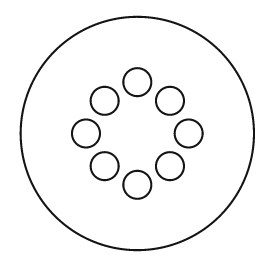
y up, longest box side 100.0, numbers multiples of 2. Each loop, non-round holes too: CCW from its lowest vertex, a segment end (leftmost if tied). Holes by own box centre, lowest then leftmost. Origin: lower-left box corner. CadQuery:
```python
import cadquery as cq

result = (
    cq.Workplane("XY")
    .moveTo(50.0, 50.0)
    .circle(50.0)
    .moveTo(50.0, 28.0)
    .circle(6.0)
    .moveTo(36.0, 36.0)
    .circle(6.0)
    .moveTo(64.0, 36.0)
    .circle(6.0)
    .moveTo(28.0, 50.0)
    .circle(6.0)
    .moveTo(72.0, 50.0)
    .circle(6.0)
    .moveTo(36.0, 64.0)
    .circle(6.0)
    .moveTo(64.0, 64.0)
    .circle(6.0)
    .moveTo(50.0, 72.0)
    .circle(6.0)
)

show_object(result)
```